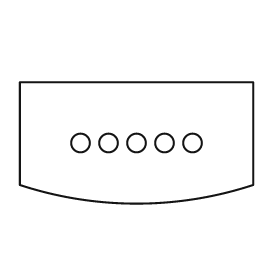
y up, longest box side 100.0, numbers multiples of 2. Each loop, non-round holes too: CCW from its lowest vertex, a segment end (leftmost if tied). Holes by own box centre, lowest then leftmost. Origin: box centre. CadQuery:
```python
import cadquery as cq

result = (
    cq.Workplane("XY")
    .moveTo(-50.0, -18.0)
    .threePointArc((0.0, -26.0), (50.0, -18.0))
    .lineTo(50.0, 26.0)
    .lineTo(-50.0, 26.0)
    .close()
    .moveTo(-24.0, 0.0)
    .circle(4.0)
    .moveTo(-12.0, 0.0)
    .circle(4.0)
    .moveTo(0.0, 0.0)
    .circle(4.0)
    .moveTo(12.0, 0.0)
    .circle(4.0)
    .moveTo(24.0, 0.0)
    .circle(4.0)
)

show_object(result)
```